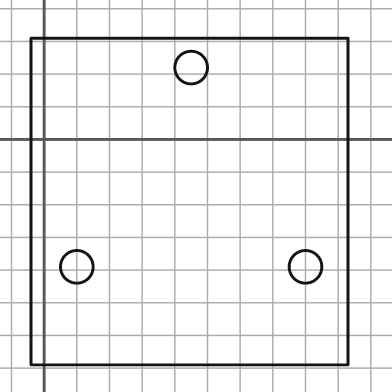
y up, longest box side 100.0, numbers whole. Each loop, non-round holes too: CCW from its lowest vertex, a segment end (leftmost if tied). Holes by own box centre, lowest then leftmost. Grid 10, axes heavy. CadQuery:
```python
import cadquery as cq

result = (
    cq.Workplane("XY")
    .moveTo(-4.0, -69.0)
    .lineTo(93.0, -69.0)
    .lineTo(93.0, 31.0)
    .lineTo(-4.0, 31.0)
    .close()
    .moveTo(10.0, -39.0)
    .circle(5.0)
    .moveTo(80.0, -39.0)
    .circle(5.0)
    .moveTo(45.0, 22.0)
    .circle(5.0)
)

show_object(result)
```